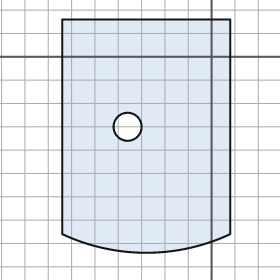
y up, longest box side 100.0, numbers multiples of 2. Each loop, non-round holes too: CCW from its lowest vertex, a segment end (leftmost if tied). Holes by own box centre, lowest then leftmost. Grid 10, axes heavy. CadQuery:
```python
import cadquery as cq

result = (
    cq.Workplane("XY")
    .moveTo(-64.0, -76.0)
    .threePointArc((-28.0, -84.0), (8.0, -76.0))
    .lineTo(8.0, 16.0)
    .lineTo(-64.0, 16.0)
    .close()
    .moveTo(-36.0, -30.0)
    .circle(6.0)
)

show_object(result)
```